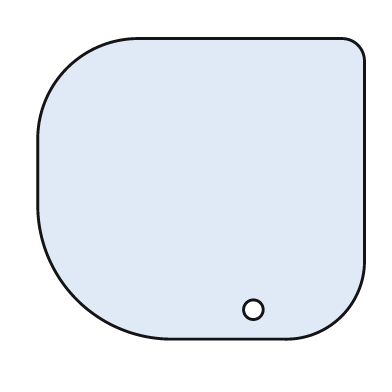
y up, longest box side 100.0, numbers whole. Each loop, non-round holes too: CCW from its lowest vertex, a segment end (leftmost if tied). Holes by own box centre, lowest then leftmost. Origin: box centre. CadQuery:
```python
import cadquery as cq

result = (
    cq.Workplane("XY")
    .moveTo(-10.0, -46.0)
    .lineTo(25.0, -46.0)
    .threePointArc((43.0, -39.0), (50.0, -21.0))
    .lineTo(50.0, 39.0)
    .threePointArc((48.0, 44.0), (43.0, 46.0))
    .lineTo(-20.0, 46.0)
    .threePointArc((-41.0, 37.0), (-50.0, 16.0))
    .lineTo(-50.0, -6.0)
    .threePointArc((-38.0, -34.0), (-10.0, -46.0))
    .close()
    .moveTo(16.0, -37.0)
    .circle(3.0)
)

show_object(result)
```